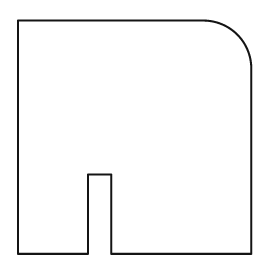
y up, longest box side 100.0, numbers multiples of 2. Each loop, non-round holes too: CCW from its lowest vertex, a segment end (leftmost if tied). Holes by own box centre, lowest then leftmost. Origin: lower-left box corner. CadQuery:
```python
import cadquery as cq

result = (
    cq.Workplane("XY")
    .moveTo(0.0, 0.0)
    .lineTo(30.0, 0.0)
    .lineTo(30.0, 34.0)
    .lineTo(40.0, 34.0)
    .lineTo(40.0, 0.0)
    .lineTo(100.0, 0.0)
    .lineTo(100.0, 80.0)
    .threePointArc((94.0, 94.0), (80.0, 100.0))
    .lineTo(0.0, 100.0)
    .close()
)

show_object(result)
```